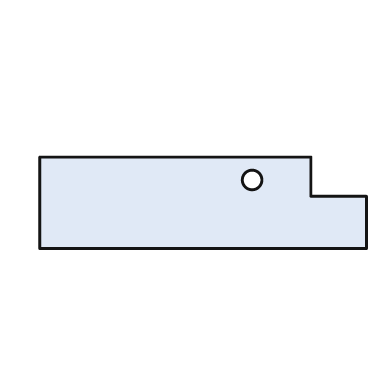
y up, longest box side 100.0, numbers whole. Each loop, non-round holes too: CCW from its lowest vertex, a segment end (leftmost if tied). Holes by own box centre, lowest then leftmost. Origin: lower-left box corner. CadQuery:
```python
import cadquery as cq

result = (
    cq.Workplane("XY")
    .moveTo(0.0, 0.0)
    .lineTo(100.0, 0.0)
    .lineTo(100.0, 16.0)
    .lineTo(83.0, 16.0)
    .lineTo(83.0, 28.0)
    .lineTo(0.0, 28.0)
    .close()
    .moveTo(65.0, 21.0)
    .circle(3.0)
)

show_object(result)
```